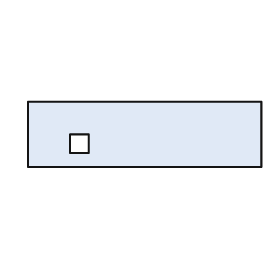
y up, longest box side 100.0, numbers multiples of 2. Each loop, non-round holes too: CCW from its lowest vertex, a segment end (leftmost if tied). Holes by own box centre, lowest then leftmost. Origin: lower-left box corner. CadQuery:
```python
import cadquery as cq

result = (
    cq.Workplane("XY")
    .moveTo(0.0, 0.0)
    .lineTo(100.0, 0.0)
    .lineTo(100.0, 28.0)
    .lineTo(0.0, 28.0)
    .close()
    .moveTo(18.0, 6.0)
    .lineTo(26.0, 6.0)
    .lineTo(26.0, 14.0)
    .lineTo(18.0, 14.0)
    .close()
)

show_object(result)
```